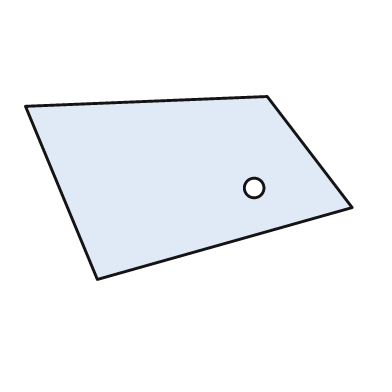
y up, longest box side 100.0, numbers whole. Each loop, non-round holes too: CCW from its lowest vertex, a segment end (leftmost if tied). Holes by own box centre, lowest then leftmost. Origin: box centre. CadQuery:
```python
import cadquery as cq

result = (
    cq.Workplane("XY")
    .moveTo(-28.0, -28.0)
    .lineTo(50.0, -6.0)
    .lineTo(24.0, 28.0)
    .lineTo(-50.0, 25.0)
    .close()
    .moveTo(20.0, 0.0)
    .circle(3.0)
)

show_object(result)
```